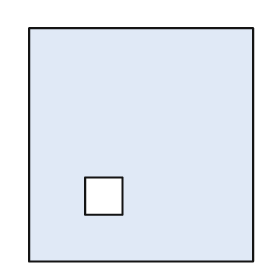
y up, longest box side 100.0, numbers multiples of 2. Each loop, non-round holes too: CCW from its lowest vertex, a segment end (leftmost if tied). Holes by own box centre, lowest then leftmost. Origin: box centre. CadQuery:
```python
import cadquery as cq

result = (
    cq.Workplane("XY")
    .moveTo(-48.0, -50.0)
    .lineTo(48.0, -50.0)
    .lineTo(48.0, 50.0)
    .lineTo(-48.0, 50.0)
    .close()
    .moveTo(-24.0, -30.0)
    .lineTo(-8.0, -30.0)
    .lineTo(-8.0, -14.0)
    .lineTo(-24.0, -14.0)
    .close()
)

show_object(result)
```